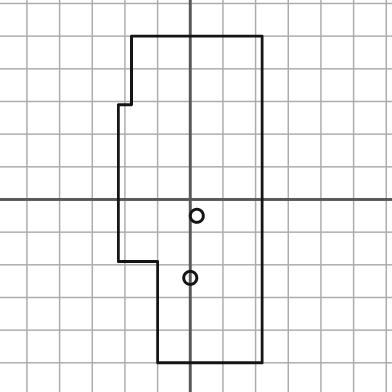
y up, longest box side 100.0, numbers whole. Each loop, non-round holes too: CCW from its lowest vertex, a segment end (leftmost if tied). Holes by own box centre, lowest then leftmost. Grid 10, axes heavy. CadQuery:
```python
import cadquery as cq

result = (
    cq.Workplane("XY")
    .moveTo(-10.0, -50.0)
    .lineTo(22.0, -50.0)
    .lineTo(22.0, 50.0)
    .lineTo(-18.0, 50.0)
    .lineTo(-18.0, 29.0)
    .lineTo(-22.0, 29.0)
    .lineTo(-22.0, -19.0)
    .lineTo(-10.0, -19.0)
    .close()
    .moveTo(0.0, -24.0)
    .circle(2.0)
    .moveTo(2.0, -5.0)
    .circle(2.0)
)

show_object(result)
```